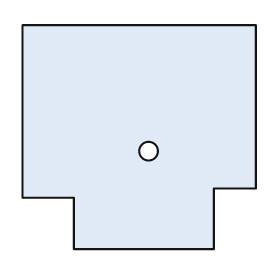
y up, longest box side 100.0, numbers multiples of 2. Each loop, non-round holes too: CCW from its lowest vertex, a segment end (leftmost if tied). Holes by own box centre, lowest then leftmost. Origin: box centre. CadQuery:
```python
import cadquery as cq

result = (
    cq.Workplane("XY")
    .moveTo(-28.0, -48.0)
    .lineTo(32.0, -48.0)
    .lineTo(32.0, -22.0)
    .lineTo(50.0, -22.0)
    .lineTo(50.0, 48.0)
    .lineTo(-50.0, 48.0)
    .lineTo(-50.0, -26.0)
    .lineTo(-28.0, -26.0)
    .close()
    .moveTo(4.0, -6.0)
    .circle(4.0)
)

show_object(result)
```